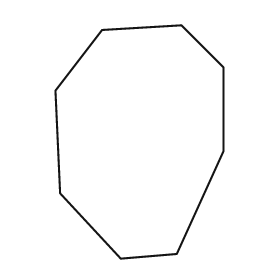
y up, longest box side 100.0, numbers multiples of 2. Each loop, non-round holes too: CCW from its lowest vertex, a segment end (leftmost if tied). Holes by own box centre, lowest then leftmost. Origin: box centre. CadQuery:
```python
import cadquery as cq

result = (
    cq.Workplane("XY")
    .moveTo(-8.0, -50.0)
    .lineTo(16.0, -48.0)
    .lineTo(36.0, -4.0)
    .lineTo(36.0, 32.0)
    .lineTo(18.0, 50.0)
    .lineTo(-16.0, 48.0)
    .lineTo(-36.0, 22.0)
    .lineTo(-34.0, -22.0)
    .close()
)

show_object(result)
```